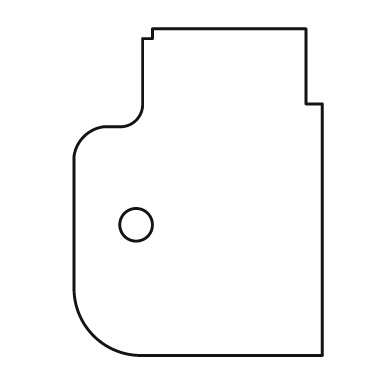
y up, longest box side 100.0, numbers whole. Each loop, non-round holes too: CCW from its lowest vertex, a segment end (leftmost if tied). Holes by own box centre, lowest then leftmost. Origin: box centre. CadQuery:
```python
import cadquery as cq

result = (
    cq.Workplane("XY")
    .moveTo(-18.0, -50.0)
    .lineTo(38.0, -50.0)
    .lineTo(38.0, 27.0)
    .lineTo(33.0, 27.0)
    .lineTo(33.0, 50.0)
    .lineTo(-14.0, 50.0)
    .lineTo(-14.0, 47.0)
    .lineTo(-17.0, 47.0)
    .lineTo(-17.0, 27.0)
    .threePointArc((-19.0, 22.0), (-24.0, 20.0))
    .lineTo(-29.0, 20.0)
    .threePointArc((-35.0, 17.0), (-38.0, 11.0))
    .lineTo(-38.0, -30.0)
    .threePointArc((-32.0, -44.0), (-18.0, -50.0))
    .close()
    .moveTo(-19.0, -10.0)
    .circle(5.0)
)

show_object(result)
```